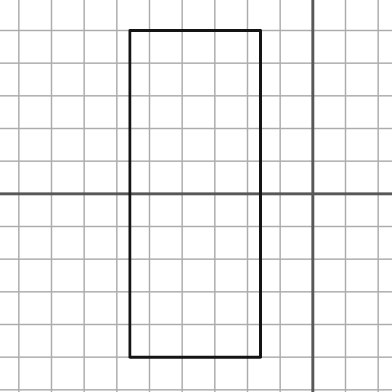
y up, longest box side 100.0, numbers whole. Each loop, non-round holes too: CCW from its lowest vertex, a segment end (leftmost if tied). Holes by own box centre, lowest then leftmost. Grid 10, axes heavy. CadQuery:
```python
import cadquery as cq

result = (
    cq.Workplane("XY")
    .moveTo(-56.0, -50.0)
    .lineTo(-16.0, -50.0)
    .lineTo(-16.0, 50.0)
    .lineTo(-56.0, 50.0)
    .close()
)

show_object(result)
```